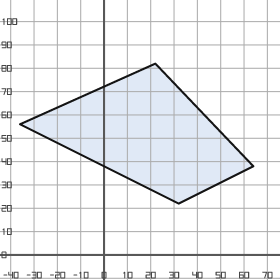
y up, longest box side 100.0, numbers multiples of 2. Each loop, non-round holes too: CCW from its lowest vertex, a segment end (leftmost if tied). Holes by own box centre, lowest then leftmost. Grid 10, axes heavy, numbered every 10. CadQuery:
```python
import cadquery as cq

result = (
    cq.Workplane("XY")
    .moveTo(32.0, 22.0)
    .lineTo(64.0, 38.0)
    .lineTo(22.0, 82.0)
    .lineTo(-36.0, 56.0)
    .close()
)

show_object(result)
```